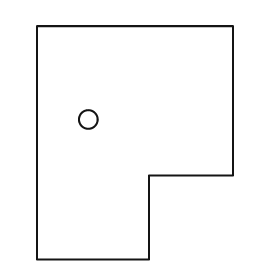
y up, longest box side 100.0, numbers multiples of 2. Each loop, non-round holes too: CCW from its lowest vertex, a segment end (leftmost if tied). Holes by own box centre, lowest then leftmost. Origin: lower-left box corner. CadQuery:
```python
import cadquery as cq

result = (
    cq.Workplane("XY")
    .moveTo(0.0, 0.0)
    .lineTo(48.0, 0.0)
    .lineTo(48.0, 36.0)
    .lineTo(84.0, 36.0)
    .lineTo(84.0, 100.0)
    .lineTo(0.0, 100.0)
    .close()
    .moveTo(22.0, 60.0)
    .circle(4.0)
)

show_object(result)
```